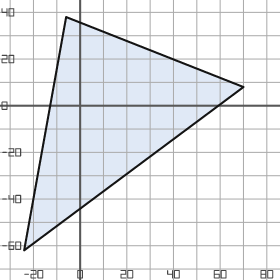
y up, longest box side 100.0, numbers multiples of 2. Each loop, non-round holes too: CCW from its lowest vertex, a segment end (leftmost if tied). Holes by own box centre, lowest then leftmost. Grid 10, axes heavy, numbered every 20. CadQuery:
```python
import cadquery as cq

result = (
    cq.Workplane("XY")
    .moveTo(-24.0, -62.0)
    .lineTo(70.0, 8.0)
    .lineTo(-6.0, 38.0)
    .close()
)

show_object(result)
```